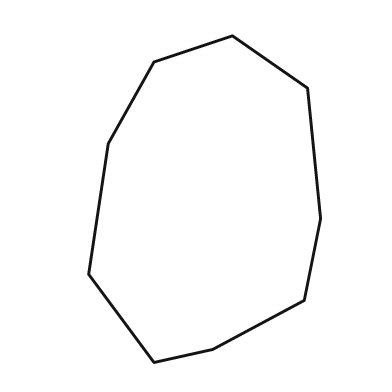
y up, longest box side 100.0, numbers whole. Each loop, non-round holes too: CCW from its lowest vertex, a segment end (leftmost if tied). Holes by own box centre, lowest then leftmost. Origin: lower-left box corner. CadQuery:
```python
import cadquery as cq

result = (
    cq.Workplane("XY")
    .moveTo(20.0, 0.0)
    .lineTo(38.0, 4.0)
    .lineTo(66.0, 19.0)
    .lineTo(71.0, 44.0)
    .lineTo(67.0, 84.0)
    .lineTo(44.0, 100.0)
    .lineTo(20.0, 92.0)
    .lineTo(6.0, 67.0)
    .lineTo(0.0, 27.0)
    .close()
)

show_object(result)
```